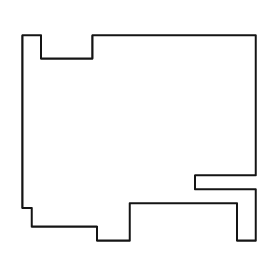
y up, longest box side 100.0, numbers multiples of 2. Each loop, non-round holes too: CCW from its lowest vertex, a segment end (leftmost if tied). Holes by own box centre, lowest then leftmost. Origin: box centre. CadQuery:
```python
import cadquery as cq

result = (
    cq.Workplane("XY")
    .moveTo(-18.0, -44.0)
    .lineTo(-4.0, -44.0)
    .lineTo(-4.0, -28.0)
    .lineTo(42.0, -28.0)
    .lineTo(42.0, -44.0)
    .lineTo(50.0, -44.0)
    .lineTo(50.0, -22.0)
    .lineTo(24.0, -22.0)
    .lineTo(24.0, -16.0)
    .lineTo(50.0, -16.0)
    .lineTo(50.0, 44.0)
    .lineTo(-20.0, 44.0)
    .lineTo(-20.0, 34.0)
    .lineTo(-42.0, 34.0)
    .lineTo(-42.0, 44.0)
    .lineTo(-50.0, 44.0)
    .lineTo(-50.0, -30.0)
    .lineTo(-46.0, -30.0)
    .lineTo(-46.0, -38.0)
    .lineTo(-18.0, -38.0)
    .close()
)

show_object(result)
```